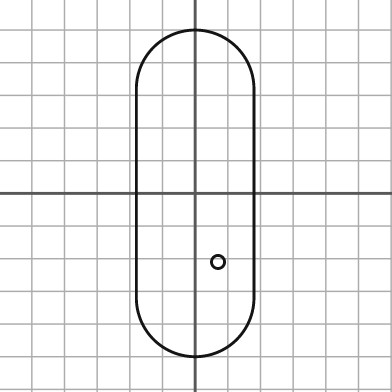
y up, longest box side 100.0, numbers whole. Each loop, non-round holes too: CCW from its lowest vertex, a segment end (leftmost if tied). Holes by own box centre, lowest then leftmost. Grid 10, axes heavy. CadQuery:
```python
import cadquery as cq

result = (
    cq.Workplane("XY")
    .moveTo(-18.0, -32.0)
    .threePointArc((0.0, -50.0), (18.0, -32.0))
    .lineTo(18.0, 32.0)
    .threePointArc((0.0, 50.0), (-18.0, 32.0))
    .close()
    .moveTo(7.0, -21.0)
    .circle(2.0)
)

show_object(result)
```